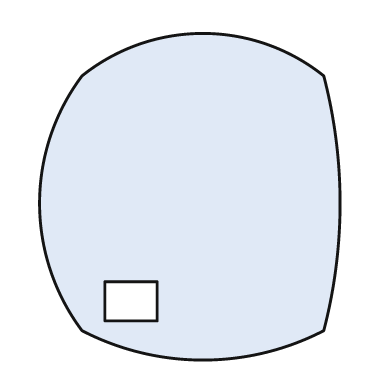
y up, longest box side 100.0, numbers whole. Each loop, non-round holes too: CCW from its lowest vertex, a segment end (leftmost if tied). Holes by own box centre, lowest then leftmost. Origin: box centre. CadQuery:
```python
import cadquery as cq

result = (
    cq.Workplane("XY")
    .moveTo(-33.0, -41.0)
    .threePointArc((4.0, -50.0), (41.0, -41.0))
    .threePointArc((46.0, -2.0), (41.0, 37.0))
    .threePointArc((4.0, 50.0), (-33.0, 37.0))
    .threePointArc((-46.0, -2.0), (-33.0, -41.0))
    .close()
    .moveTo(-26.0, -38.0)
    .lineTo(-10.0, -38.0)
    .lineTo(-10.0, -26.0)
    .lineTo(-26.0, -26.0)
    .close()
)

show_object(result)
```